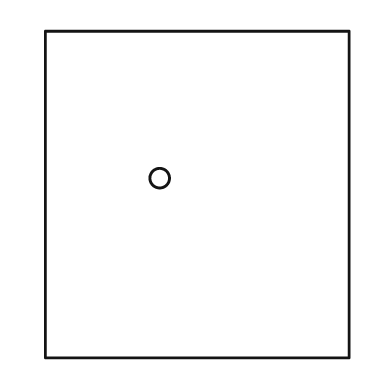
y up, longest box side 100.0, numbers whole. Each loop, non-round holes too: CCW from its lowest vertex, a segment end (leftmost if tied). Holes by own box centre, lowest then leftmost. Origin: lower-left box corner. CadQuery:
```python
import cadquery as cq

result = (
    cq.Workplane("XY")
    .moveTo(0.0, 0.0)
    .lineTo(93.0, 0.0)
    .lineTo(93.0, 100.0)
    .lineTo(0.0, 100.0)
    .close()
    .moveTo(35.0, 55.0)
    .circle(3.0)
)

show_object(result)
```